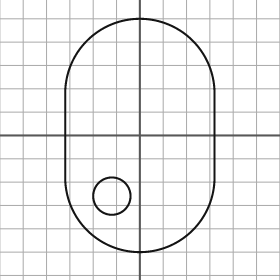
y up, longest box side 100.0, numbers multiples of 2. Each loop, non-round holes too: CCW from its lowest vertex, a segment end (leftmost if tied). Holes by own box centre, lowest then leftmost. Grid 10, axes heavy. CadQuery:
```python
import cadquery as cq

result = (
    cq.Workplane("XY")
    .moveTo(-32.0, -18.0)
    .threePointArc((0.0, -50.0), (32.0, -18.0))
    .lineTo(32.0, 18.0)
    .threePointArc((0.0, 50.0), (-32.0, 18.0))
    .close()
    .moveTo(-12.0, -26.0)
    .circle(8.0)
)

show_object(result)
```